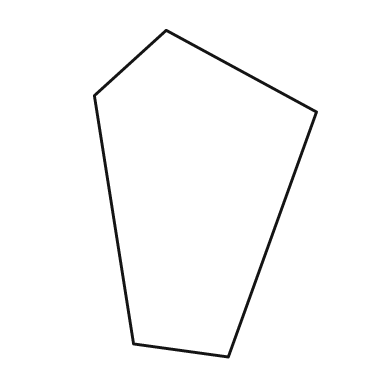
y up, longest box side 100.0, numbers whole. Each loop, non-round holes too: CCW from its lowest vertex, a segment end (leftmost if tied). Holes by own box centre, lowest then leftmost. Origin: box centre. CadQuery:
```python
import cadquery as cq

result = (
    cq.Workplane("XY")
    .moveTo(7.0, -50.0)
    .lineTo(34.0, 25.0)
    .lineTo(-12.0, 50.0)
    .lineTo(-34.0, 30.0)
    .lineTo(-22.0, -46.0)
    .close()
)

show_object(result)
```